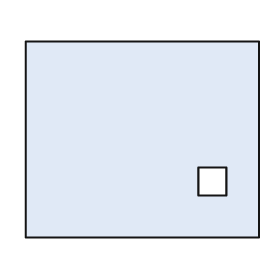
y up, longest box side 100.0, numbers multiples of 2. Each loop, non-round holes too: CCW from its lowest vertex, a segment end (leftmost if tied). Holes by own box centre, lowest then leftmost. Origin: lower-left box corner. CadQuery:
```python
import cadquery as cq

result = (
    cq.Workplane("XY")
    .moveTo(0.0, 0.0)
    .lineTo(100.0, 0.0)
    .lineTo(100.0, 84.0)
    .lineTo(0.0, 84.0)
    .close()
    .moveTo(74.0, 18.0)
    .lineTo(86.0, 18.0)
    .lineTo(86.0, 30.0)
    .lineTo(74.0, 30.0)
    .close()
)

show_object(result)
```